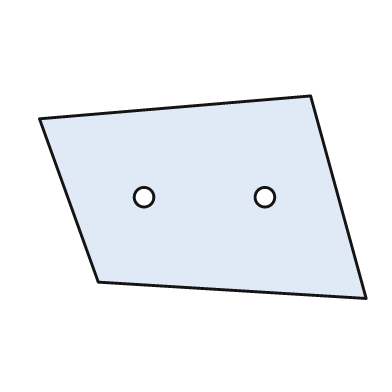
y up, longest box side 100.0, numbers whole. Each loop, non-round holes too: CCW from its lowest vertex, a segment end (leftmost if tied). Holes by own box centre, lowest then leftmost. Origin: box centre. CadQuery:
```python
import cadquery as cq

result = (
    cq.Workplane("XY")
    .moveTo(50.0, -31.0)
    .lineTo(33.0, 31.0)
    .lineTo(-50.0, 24.0)
    .lineTo(-32.0, -26.0)
    .close()
    .moveTo(-18.0, 0.0)
    .circle(3.0)
    .moveTo(19.0, 0.0)
    .circle(3.0)
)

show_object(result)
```